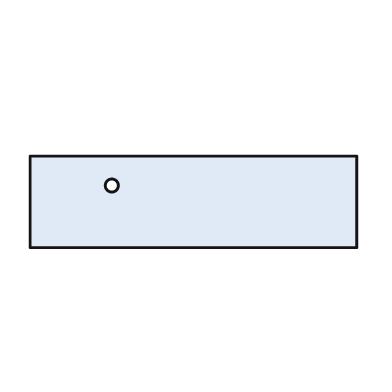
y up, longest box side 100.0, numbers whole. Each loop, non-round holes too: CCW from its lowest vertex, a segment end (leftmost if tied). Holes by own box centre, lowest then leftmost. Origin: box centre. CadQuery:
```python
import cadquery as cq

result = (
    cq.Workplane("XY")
    .moveTo(-50.0, -14.0)
    .lineTo(50.0, -14.0)
    .lineTo(50.0, 14.0)
    .lineTo(-50.0, 14.0)
    .close()
    .moveTo(-25.0, 5.0)
    .circle(2.0)
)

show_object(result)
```